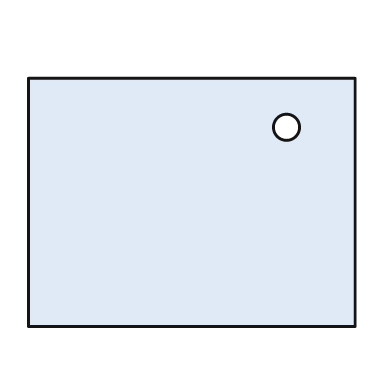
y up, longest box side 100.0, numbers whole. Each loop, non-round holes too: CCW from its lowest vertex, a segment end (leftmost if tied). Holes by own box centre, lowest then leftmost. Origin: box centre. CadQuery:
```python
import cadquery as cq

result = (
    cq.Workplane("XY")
    .moveTo(-50.0, -38.0)
    .lineTo(50.0, -38.0)
    .lineTo(50.0, 38.0)
    .lineTo(-50.0, 38.0)
    .close()
    .moveTo(29.0, 23.0)
    .circle(4.0)
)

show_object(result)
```